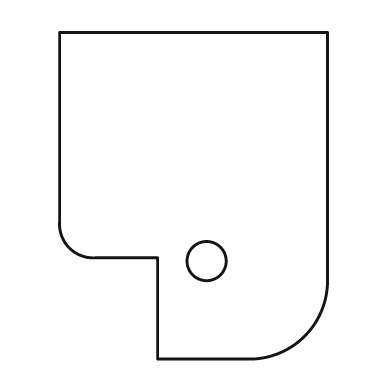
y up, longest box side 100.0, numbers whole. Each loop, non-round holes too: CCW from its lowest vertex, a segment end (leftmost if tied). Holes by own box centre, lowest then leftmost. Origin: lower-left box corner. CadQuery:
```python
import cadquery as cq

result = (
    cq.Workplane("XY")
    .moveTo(30.0, 0.0)
    .lineTo(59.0, 0.0)
    .threePointArc((75.0, 7.0), (82.0, 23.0))
    .lineTo(82.0, 100.0)
    .lineTo(0.0, 100.0)
    .lineTo(0.0, 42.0)
    .threePointArc((3.0, 34.0), (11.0, 31.0))
    .lineTo(30.0, 31.0)
    .close()
    .moveTo(45.0, 30.0)
    .circle(6.0)
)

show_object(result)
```